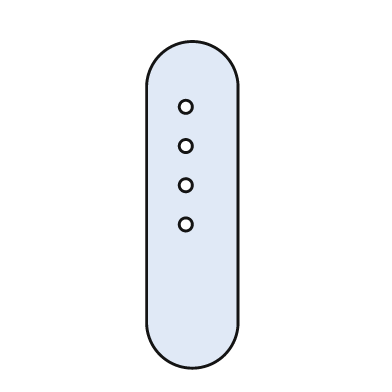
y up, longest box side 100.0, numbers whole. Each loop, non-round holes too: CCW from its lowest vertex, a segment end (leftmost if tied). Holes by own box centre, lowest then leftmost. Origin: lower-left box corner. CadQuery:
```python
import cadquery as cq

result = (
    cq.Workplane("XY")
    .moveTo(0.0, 14.0)
    .threePointArc((14.0, 0.0), (28.0, 14.0))
    .lineTo(28.0, 86.0)
    .threePointArc((14.0, 100.0), (0.0, 86.0))
    .close()
    .moveTo(12.0, 44.0)
    .circle(2.0)
    .moveTo(12.0, 56.0)
    .circle(2.0)
    .moveTo(12.0, 68.0)
    .circle(2.0)
    .moveTo(12.0, 80.0)
    .circle(2.0)
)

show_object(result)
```